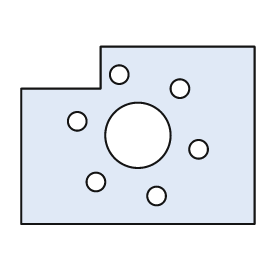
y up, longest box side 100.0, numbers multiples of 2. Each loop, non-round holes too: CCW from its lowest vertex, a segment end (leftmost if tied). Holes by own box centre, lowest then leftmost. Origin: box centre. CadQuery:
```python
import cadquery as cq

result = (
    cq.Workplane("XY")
    .moveTo(-50.0, -38.0)
    .lineTo(50.0, -38.0)
    .lineTo(50.0, 38.0)
    .lineTo(-16.0, 38.0)
    .lineTo(-16.0, 20.0)
    .lineTo(-50.0, 20.0)
    .close()
    .moveTo(8.0, -26.0)
    .circle(4.0)
    .moveTo(-18.0, -20.0)
    .circle(4.0)
    .moveTo(26.0, -6.0)
    .circle(4.0)
    .moveTo(0.0, 0.0)
    .circle(14.0)
    .moveTo(-26.0, 6.0)
    .circle(4.0)
    .moveTo(18.0, 20.0)
    .circle(4.0)
    .moveTo(-8.0, 26.0)
    .circle(4.0)
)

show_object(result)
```